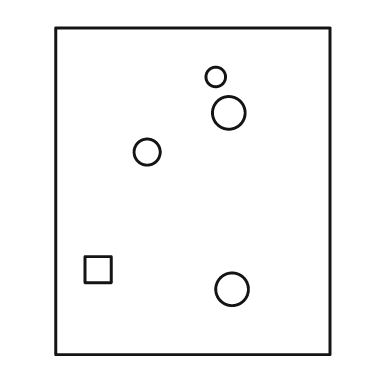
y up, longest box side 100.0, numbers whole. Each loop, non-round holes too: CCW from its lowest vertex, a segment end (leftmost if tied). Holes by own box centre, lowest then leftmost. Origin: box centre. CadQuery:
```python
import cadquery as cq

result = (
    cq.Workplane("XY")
    .moveTo(-42.0, -50.0)
    .lineTo(42.0, -50.0)
    .lineTo(42.0, 50.0)
    .lineTo(-42.0, 50.0)
    .close()
    .moveTo(12.0, -30.0)
    .circle(5.0)
    .moveTo(-33.0, -28.0)
    .lineTo(-25.0, -28.0)
    .lineTo(-25.0, -20.0)
    .lineTo(-33.0, -20.0)
    .close()
    .moveTo(-14.0, 12.0)
    .circle(4.0)
    .moveTo(11.0, 24.0)
    .circle(5.0)
    .moveTo(7.0, 35.0)
    .circle(3.0)
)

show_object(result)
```